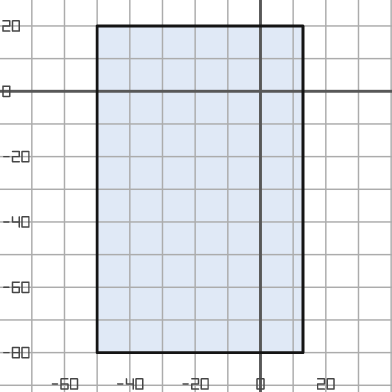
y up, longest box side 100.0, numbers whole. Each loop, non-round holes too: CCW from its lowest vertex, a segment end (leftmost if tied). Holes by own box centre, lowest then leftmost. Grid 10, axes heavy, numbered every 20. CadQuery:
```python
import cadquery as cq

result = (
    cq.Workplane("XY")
    .moveTo(-50.0, -80.0)
    .lineTo(13.0, -80.0)
    .lineTo(13.0, 20.0)
    .lineTo(-50.0, 20.0)
    .close()
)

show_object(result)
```